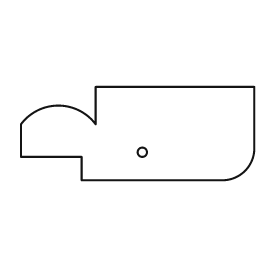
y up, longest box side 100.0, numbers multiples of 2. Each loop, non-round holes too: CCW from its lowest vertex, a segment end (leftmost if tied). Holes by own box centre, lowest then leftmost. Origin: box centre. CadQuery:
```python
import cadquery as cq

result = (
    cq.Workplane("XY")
    .moveTo(-24.0, -20.0)
    .lineTo(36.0, -20.0)
    .threePointArc((46.0, -16.0), (50.0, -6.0))
    .lineTo(50.0, 20.0)
    .lineTo(-18.0, 20.0)
    .lineTo(-18.0, 4.0)
    .threePointArc((-34.0, 12.0), (-50.0, 4.0))
    .lineTo(-50.0, -10.0)
    .lineTo(-24.0, -10.0)
    .close()
    .moveTo(2.0, -8.0)
    .circle(2.0)
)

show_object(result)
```